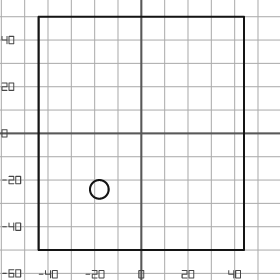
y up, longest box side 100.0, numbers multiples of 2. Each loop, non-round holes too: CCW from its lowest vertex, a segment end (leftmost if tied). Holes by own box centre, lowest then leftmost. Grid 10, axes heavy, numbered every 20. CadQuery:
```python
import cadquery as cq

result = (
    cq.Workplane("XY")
    .moveTo(-44.0, -50.0)
    .lineTo(44.0, -50.0)
    .lineTo(44.0, 50.0)
    .lineTo(-44.0, 50.0)
    .close()
    .moveTo(-18.0, -24.0)
    .circle(4.0)
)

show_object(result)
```